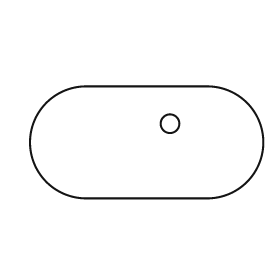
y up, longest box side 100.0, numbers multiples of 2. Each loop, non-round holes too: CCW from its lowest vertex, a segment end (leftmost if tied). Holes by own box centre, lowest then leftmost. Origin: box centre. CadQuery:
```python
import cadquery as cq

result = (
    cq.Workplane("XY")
    .moveTo(-26.0, -24.0)
    .lineTo(26.0, -24.0)
    .threePointArc((50.0, 0.0), (26.0, 24.0))
    .lineTo(-26.0, 24.0)
    .threePointArc((-50.0, 0.0), (-26.0, -24.0))
    .close()
    .moveTo(10.0, 8.0)
    .circle(4.0)
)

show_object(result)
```